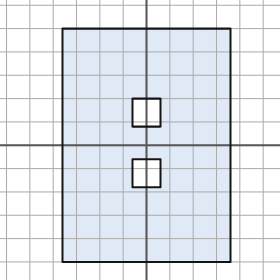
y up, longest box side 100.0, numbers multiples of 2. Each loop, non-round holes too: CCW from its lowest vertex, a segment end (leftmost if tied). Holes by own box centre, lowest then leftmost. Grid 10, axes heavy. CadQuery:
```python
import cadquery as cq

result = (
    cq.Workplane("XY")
    .moveTo(-36.0, -50.0)
    .lineTo(36.0, -50.0)
    .lineTo(36.0, 50.0)
    .lineTo(-36.0, 50.0)
    .close()
    .moveTo(-6.0, -18.0)
    .lineTo(6.0, -18.0)
    .lineTo(6.0, -6.0)
    .lineTo(-6.0, -6.0)
    .close()
    .moveTo(-6.0, 8.0)
    .lineTo(6.0, 8.0)
    .lineTo(6.0, 20.0)
    .lineTo(-6.0, 20.0)
    .close()
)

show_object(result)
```